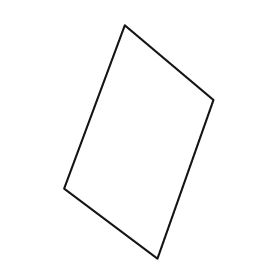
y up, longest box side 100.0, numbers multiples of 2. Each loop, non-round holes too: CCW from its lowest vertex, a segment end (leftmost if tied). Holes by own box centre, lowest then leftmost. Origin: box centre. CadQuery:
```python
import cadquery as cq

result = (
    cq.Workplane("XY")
    .moveTo(8.0, -50.0)
    .lineTo(32.0, 18.0)
    .lineTo(-6.0, 50.0)
    .lineTo(-32.0, -20.0)
    .close()
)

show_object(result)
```